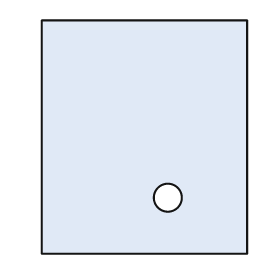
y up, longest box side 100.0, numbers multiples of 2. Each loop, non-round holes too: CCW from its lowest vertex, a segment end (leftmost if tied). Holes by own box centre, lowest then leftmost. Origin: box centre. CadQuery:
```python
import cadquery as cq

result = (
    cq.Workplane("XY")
    .moveTo(-44.0, -50.0)
    .lineTo(44.0, -50.0)
    .lineTo(44.0, 50.0)
    .lineTo(-44.0, 50.0)
    .close()
    .moveTo(10.0, -26.0)
    .circle(6.0)
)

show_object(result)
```